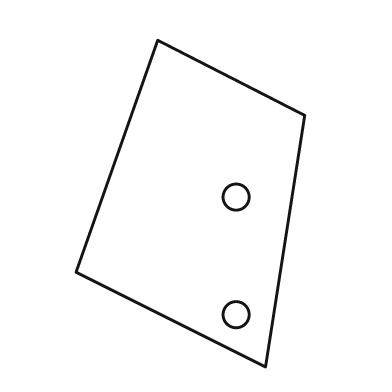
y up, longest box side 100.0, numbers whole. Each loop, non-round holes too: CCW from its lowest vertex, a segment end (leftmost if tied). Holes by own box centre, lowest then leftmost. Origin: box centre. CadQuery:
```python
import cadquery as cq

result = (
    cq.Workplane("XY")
    .moveTo(23.0, -50.0)
    .lineTo(35.0, 27.0)
    .lineTo(-10.0, 50.0)
    .lineTo(-35.0, -21.0)
    .close()
    .moveTo(14.0, -34.0)
    .circle(4.0)
    .moveTo(14.0, 2.0)
    .circle(4.0)
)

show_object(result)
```